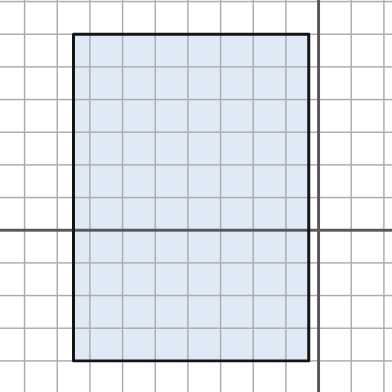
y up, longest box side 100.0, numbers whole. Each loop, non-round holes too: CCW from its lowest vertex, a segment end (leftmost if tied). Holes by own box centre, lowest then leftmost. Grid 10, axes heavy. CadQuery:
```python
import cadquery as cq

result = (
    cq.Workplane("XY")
    .moveTo(-75.0, -40.0)
    .lineTo(-3.0, -40.0)
    .lineTo(-3.0, 60.0)
    .lineTo(-75.0, 60.0)
    .close()
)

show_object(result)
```